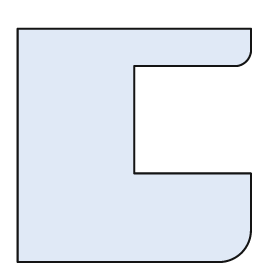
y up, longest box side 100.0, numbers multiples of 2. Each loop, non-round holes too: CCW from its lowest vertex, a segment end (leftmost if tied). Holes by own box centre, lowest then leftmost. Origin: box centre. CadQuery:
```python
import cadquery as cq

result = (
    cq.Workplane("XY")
    .moveTo(-50.0, -50.0)
    .lineTo(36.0, -50.0)
    .threePointArc((46.0, -46.0), (50.0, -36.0))
    .lineTo(50.0, -12.0)
    .lineTo(0.0, -12.0)
    .lineTo(0.0, 34.0)
    .lineTo(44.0, 34.0)
    .threePointArc((48.0, 36.0), (50.0, 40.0))
    .lineTo(50.0, 50.0)
    .lineTo(-50.0, 50.0)
    .close()
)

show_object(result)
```